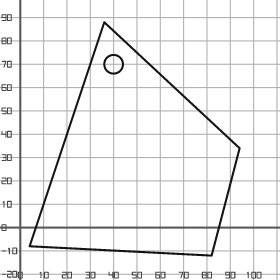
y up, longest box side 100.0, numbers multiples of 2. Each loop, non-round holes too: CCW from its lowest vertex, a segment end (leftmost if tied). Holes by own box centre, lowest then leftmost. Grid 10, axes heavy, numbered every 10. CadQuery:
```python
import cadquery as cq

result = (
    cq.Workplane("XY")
    .moveTo(82.0, -12.0)
    .lineTo(94.0, 34.0)
    .lineTo(36.0, 88.0)
    .lineTo(4.0, -8.0)
    .close()
    .moveTo(40.0, 70.0)
    .circle(4.0)
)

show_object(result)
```